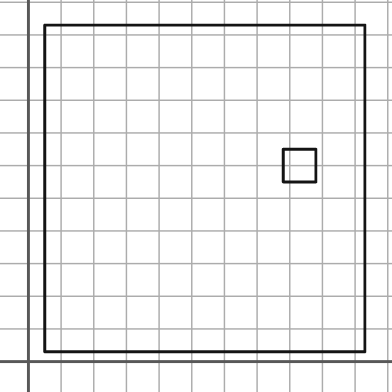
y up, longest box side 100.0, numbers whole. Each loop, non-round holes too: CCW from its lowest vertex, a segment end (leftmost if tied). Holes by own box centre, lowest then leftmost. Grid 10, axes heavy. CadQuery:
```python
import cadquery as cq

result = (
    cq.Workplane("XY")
    .moveTo(5.0, 3.0)
    .lineTo(103.0, 3.0)
    .lineTo(103.0, 103.0)
    .lineTo(5.0, 103.0)
    .close()
    .moveTo(78.0, 55.0)
    .lineTo(88.0, 55.0)
    .lineTo(88.0, 65.0)
    .lineTo(78.0, 65.0)
    .close()
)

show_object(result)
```